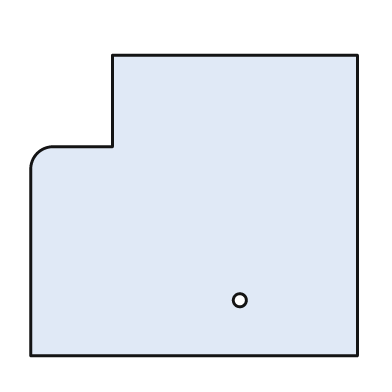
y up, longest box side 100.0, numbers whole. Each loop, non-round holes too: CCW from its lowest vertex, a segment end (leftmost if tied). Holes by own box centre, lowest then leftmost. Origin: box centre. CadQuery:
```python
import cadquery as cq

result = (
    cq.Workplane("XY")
    .moveTo(-50.0, -46.0)
    .lineTo(50.0, -46.0)
    .lineTo(50.0, 46.0)
    .lineTo(-25.0, 46.0)
    .lineTo(-25.0, 18.0)
    .lineTo(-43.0, 18.0)
    .threePointArc((-48.0, 16.0), (-50.0, 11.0))
    .close()
    .moveTo(14.0, -29.0)
    .circle(2.0)
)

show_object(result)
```